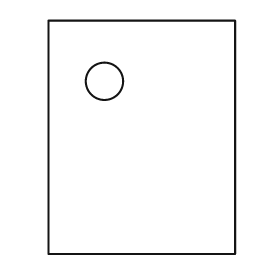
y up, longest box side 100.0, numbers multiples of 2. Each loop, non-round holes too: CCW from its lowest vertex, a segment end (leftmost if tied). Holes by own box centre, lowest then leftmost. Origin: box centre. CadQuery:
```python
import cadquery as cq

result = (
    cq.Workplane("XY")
    .moveTo(-40.0, -50.0)
    .lineTo(40.0, -50.0)
    .lineTo(40.0, 50.0)
    .lineTo(-40.0, 50.0)
    .close()
    .moveTo(-16.0, 24.0)
    .circle(8.0)
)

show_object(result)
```